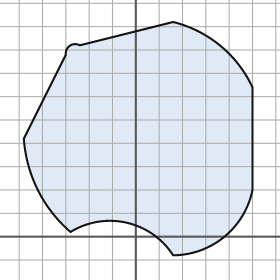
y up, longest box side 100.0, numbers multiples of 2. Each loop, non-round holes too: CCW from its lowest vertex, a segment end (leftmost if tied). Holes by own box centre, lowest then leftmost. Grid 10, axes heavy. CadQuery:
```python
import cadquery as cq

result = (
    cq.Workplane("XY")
    .moveTo(16.0, -8.0)
    .threePointArc((38.0, 0.0), (50.0, 20.0))
    .lineTo(50.0, 64.0)
    .threePointArc((36.0, 82.0), (16.0, 92.0))
    .lineTo(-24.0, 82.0)
    .threePointArc((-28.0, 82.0), (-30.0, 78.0))
    .lineTo(-48.0, 42.0)
    .threePointArc((-42.0, 20.0), (-28.0, 2.0))
    .threePointArc((-4.0, 6.0), (16.0, -8.0))
    .close()
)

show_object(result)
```